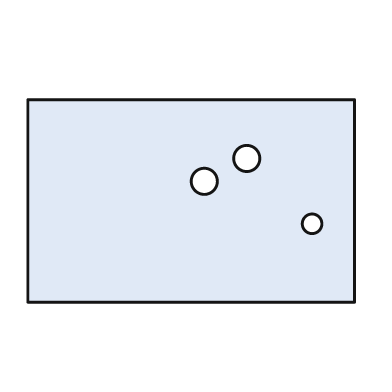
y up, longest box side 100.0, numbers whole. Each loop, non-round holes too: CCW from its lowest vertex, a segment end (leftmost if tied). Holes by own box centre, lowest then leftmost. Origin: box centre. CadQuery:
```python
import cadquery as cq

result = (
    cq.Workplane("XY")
    .moveTo(-50.0, -31.0)
    .lineTo(50.0, -31.0)
    .lineTo(50.0, 31.0)
    .lineTo(-50.0, 31.0)
    .close()
    .moveTo(37.0, -7.0)
    .circle(3.0)
    .moveTo(4.0, 6.0)
    .circle(4.0)
    .moveTo(17.0, 13.0)
    .circle(4.0)
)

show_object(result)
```